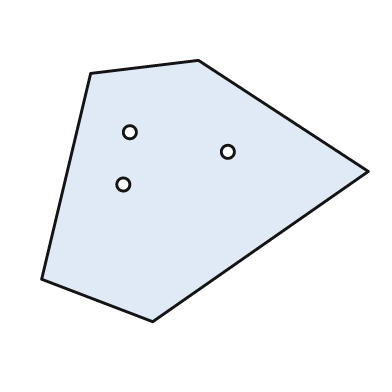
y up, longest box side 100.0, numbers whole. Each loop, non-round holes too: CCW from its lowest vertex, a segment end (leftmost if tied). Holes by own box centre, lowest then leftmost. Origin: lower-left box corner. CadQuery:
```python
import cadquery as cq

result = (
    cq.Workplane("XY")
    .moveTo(34.0, 0.0)
    .lineTo(100.0, 46.0)
    .lineTo(48.0, 80.0)
    .lineTo(15.0, 76.0)
    .lineTo(0.0, 13.0)
    .close()
    .moveTo(25.0, 42.0)
    .circle(2.0)
    .moveTo(57.0, 52.0)
    .circle(2.0)
    .moveTo(27.0, 58.0)
    .circle(2.0)
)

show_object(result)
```